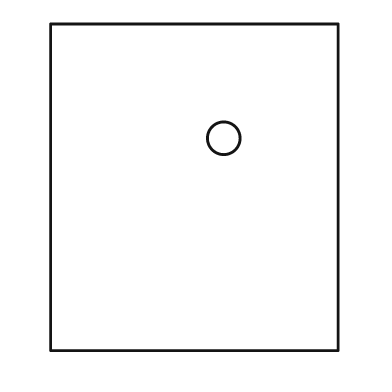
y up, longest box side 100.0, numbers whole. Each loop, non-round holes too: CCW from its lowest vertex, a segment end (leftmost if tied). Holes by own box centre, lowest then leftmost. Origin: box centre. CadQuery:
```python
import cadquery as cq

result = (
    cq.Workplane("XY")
    .moveTo(-44.0, -50.0)
    .lineTo(44.0, -50.0)
    .lineTo(44.0, 50.0)
    .lineTo(-44.0, 50.0)
    .close()
    .moveTo(9.0, 15.0)
    .circle(5.0)
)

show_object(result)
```